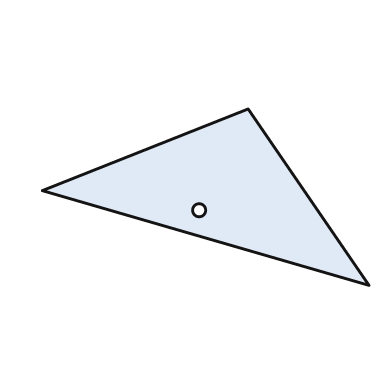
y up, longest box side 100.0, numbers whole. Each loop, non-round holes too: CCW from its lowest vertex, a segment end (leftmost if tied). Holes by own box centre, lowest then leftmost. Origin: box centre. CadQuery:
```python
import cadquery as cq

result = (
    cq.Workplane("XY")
    .moveTo(50.0, -27.0)
    .lineTo(13.0, 27.0)
    .lineTo(-50.0, 2.0)
    .close()
    .moveTo(-2.0, -4.0)
    .circle(2.0)
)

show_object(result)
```